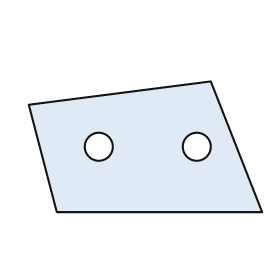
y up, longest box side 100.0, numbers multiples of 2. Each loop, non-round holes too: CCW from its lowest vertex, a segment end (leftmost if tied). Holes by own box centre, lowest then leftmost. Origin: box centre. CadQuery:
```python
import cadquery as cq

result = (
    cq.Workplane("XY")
    .moveTo(-38.0, -28.0)
    .lineTo(50.0, -28.0)
    .lineTo(28.0, 28.0)
    .lineTo(-50.0, 18.0)
    .close()
    .moveTo(-20.0, 0.0)
    .circle(6.0)
    .moveTo(22.0, 0.0)
    .circle(6.0)
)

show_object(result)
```